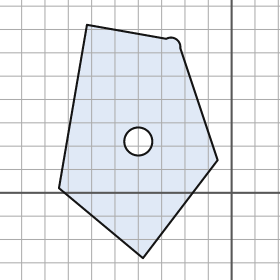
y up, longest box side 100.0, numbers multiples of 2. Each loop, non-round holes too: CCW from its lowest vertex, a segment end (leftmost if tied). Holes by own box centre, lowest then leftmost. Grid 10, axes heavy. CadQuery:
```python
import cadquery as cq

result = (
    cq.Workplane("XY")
    .moveTo(-38.0, -28.0)
    .lineTo(-6.0, 14.0)
    .lineTo(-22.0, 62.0)
    .threePointArc((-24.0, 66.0), (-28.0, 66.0))
    .lineTo(-62.0, 72.0)
    .lineTo(-74.0, 2.0)
    .close()
    .moveTo(-40.0, 22.0)
    .circle(6.0)
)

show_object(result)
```